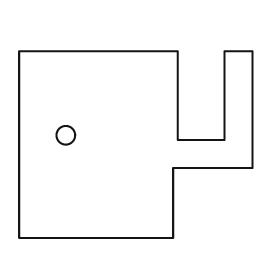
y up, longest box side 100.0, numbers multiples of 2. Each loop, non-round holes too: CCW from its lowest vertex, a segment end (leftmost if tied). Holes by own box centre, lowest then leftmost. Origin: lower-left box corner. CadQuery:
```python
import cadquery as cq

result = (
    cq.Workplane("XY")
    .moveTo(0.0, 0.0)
    .lineTo(66.0, 0.0)
    .lineTo(66.0, 30.0)
    .lineTo(100.0, 30.0)
    .lineTo(100.0, 80.0)
    .lineTo(88.0, 80.0)
    .lineTo(88.0, 42.0)
    .lineTo(68.0, 42.0)
    .lineTo(68.0, 80.0)
    .lineTo(0.0, 80.0)
    .close()
    .moveTo(20.0, 44.0)
    .circle(4.0)
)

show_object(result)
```